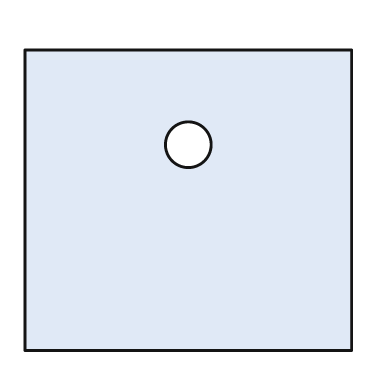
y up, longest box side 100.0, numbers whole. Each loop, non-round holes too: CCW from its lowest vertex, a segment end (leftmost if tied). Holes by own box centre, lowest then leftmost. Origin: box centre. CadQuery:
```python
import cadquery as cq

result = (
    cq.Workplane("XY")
    .moveTo(-50.0, -46.0)
    .lineTo(50.0, -46.0)
    .lineTo(50.0, 46.0)
    .lineTo(-50.0, 46.0)
    .close()
    .moveTo(0.0, 17.0)
    .circle(7.0)
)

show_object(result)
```